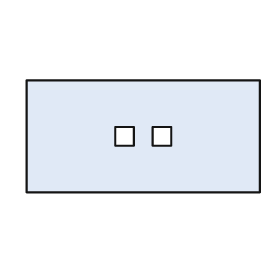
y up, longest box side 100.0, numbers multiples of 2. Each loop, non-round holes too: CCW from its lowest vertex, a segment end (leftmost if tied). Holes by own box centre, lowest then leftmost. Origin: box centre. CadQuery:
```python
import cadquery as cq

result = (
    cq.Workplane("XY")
    .moveTo(-50.0, -24.0)
    .lineTo(50.0, -24.0)
    .lineTo(50.0, 24.0)
    .lineTo(-50.0, 24.0)
    .close()
    .moveTo(-12.0, -4.0)
    .lineTo(-4.0, -4.0)
    .lineTo(-4.0, 4.0)
    .lineTo(-12.0, 4.0)
    .close()
    .moveTo(4.0, -4.0)
    .lineTo(12.0, -4.0)
    .lineTo(12.0, 4.0)
    .lineTo(4.0, 4.0)
    .close()
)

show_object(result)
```